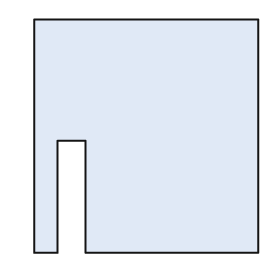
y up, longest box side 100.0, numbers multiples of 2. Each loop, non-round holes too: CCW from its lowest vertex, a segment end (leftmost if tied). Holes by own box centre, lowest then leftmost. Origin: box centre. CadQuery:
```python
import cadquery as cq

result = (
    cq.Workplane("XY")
    .moveTo(-48.0, -50.0)
    .lineTo(-38.0, -50.0)
    .lineTo(-38.0, -2.0)
    .lineTo(-26.0, -2.0)
    .lineTo(-26.0, -50.0)
    .lineTo(48.0, -50.0)
    .lineTo(48.0, 50.0)
    .lineTo(-48.0, 50.0)
    .close()
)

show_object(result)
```